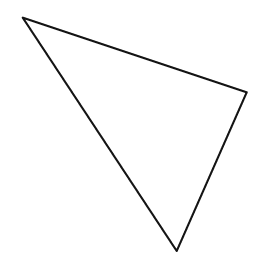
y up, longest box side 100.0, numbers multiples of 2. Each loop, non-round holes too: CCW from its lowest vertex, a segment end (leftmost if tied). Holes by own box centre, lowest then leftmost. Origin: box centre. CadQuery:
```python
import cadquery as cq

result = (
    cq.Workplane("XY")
    .moveTo(18.0, -50.0)
    .lineTo(48.0, 18.0)
    .lineTo(-48.0, 50.0)
    .close()
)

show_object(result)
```